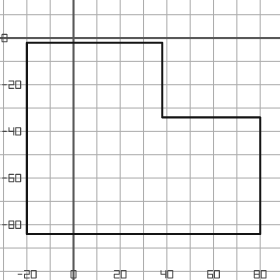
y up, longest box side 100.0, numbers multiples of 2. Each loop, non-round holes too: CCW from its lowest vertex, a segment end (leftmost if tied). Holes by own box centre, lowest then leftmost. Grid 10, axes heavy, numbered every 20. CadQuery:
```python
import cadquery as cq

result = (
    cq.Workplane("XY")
    .moveTo(-20.0, -84.0)
    .lineTo(80.0, -84.0)
    .lineTo(80.0, -34.0)
    .lineTo(38.0, -34.0)
    .lineTo(38.0, -2.0)
    .lineTo(-20.0, -2.0)
    .close()
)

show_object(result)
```